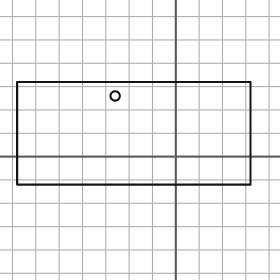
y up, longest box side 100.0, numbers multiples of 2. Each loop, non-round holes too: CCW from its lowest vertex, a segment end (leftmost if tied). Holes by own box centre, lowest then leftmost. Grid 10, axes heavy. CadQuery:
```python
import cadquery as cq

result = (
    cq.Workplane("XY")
    .moveTo(-68.0, -12.0)
    .lineTo(32.0, -12.0)
    .lineTo(32.0, 32.0)
    .lineTo(-68.0, 32.0)
    .close()
    .moveTo(-26.0, 26.0)
    .circle(2.0)
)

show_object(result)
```